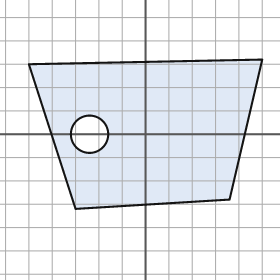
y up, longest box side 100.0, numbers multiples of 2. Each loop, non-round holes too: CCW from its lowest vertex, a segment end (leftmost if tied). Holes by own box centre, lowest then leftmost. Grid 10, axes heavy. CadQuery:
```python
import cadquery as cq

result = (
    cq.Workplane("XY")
    .moveTo(-30.0, -32.0)
    .lineTo(36.0, -28.0)
    .lineTo(50.0, 32.0)
    .lineTo(-50.0, 30.0)
    .close()
    .moveTo(-24.0, 0.0)
    .circle(8.0)
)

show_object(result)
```